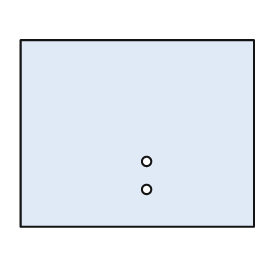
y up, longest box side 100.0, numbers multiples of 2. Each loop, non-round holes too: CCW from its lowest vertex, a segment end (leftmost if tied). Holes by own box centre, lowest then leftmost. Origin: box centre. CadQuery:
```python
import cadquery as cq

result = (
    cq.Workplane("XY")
    .moveTo(-50.0, -40.0)
    .lineTo(50.0, -40.0)
    .lineTo(50.0, 40.0)
    .lineTo(-50.0, 40.0)
    .close()
    .moveTo(4.0, -24.0)
    .circle(2.0)
    .moveTo(4.0, -12.0)
    .circle(2.0)
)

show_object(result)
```